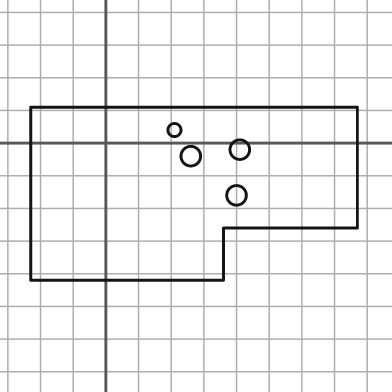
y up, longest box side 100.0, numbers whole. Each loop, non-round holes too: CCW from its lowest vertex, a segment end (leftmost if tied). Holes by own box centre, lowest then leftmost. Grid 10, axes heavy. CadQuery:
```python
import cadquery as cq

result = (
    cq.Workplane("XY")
    .moveTo(-23.0, -42.0)
    .lineTo(36.0, -42.0)
    .lineTo(36.0, -26.0)
    .lineTo(77.0, -26.0)
    .lineTo(77.0, 11.0)
    .lineTo(-23.0, 11.0)
    .close()
    .moveTo(40.0, -16.0)
    .circle(3.0)
    .moveTo(26.0, -4.0)
    .circle(3.0)
    .moveTo(41.0, -2.0)
    .circle(3.0)
    .moveTo(21.0, 4.0)
    .circle(2.0)
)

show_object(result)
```